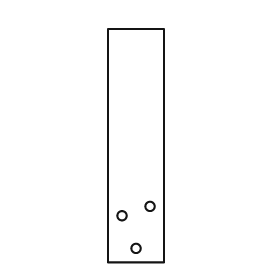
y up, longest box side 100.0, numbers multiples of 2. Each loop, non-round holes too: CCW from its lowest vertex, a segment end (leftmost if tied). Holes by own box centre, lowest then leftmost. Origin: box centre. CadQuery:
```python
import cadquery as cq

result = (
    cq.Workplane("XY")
    .moveTo(-12.0, -50.0)
    .lineTo(12.0, -50.0)
    .lineTo(12.0, 50.0)
    .lineTo(-12.0, 50.0)
    .close()
    .moveTo(0.0, -44.0)
    .circle(2.0)
    .moveTo(-6.0, -30.0)
    .circle(2.0)
    .moveTo(6.0, -26.0)
    .circle(2.0)
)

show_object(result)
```